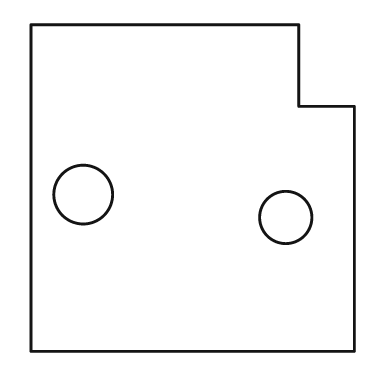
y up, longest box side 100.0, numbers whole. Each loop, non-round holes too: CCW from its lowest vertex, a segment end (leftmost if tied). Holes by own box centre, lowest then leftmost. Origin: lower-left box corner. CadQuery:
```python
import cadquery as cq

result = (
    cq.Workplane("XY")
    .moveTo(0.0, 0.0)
    .lineTo(99.0, 0.0)
    .lineTo(99.0, 75.0)
    .lineTo(82.0, 75.0)
    .lineTo(82.0, 100.0)
    .lineTo(0.0, 100.0)
    .close()
    .moveTo(78.0, 41.0)
    .circle(8.0)
    .moveTo(16.0, 48.0)
    .circle(9.0)
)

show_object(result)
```